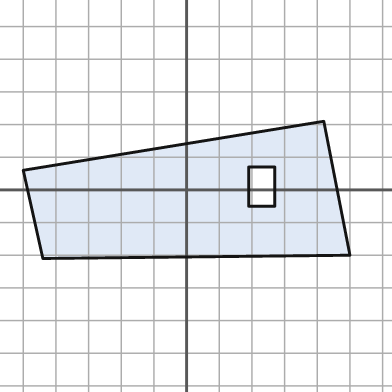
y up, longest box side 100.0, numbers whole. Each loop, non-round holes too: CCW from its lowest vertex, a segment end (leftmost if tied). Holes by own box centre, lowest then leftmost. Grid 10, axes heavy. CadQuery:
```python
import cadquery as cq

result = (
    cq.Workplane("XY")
    .moveTo(-44.0, -21.0)
    .lineTo(50.0, -20.0)
    .lineTo(42.0, 21.0)
    .lineTo(-50.0, 6.0)
    .close()
    .moveTo(19.0, -5.0)
    .lineTo(27.0, -5.0)
    .lineTo(27.0, 7.0)
    .lineTo(19.0, 7.0)
    .close()
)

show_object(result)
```